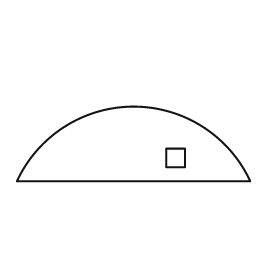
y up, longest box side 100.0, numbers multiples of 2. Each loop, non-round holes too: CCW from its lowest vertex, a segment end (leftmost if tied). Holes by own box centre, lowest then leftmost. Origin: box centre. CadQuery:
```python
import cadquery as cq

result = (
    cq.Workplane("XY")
    .moveTo(-50.0, -16.0)
    .lineTo(50.0, -16.0)
    .threePointArc((0.0, 16.0), (-50.0, -16.0))
    .close()
    .moveTo(14.0, -10.0)
    .lineTo(22.0, -10.0)
    .lineTo(22.0, -2.0)
    .lineTo(14.0, -2.0)
    .close()
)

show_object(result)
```